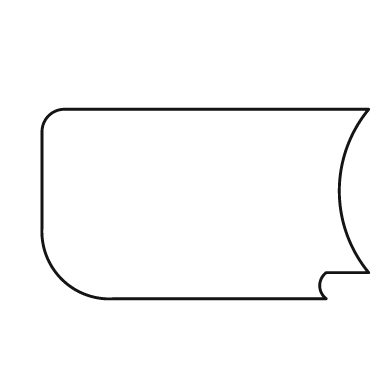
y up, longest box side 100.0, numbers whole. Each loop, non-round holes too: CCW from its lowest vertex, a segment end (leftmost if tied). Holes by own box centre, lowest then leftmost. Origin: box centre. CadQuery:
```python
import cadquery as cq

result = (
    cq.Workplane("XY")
    .moveTo(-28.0, -29.0)
    .lineTo(37.0, -29.0)
    .threePointArc((35.0, -25.0), (37.0, -21.0))
    .lineTo(50.0, -21.0)
    .threePointArc((41.0, 4.0), (50.0, 29.0))
    .lineTo(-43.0, 29.0)
    .threePointArc((-48.0, 27.0), (-50.0, 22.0))
    .lineTo(-50.0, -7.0)
    .threePointArc((-44.0, -23.0), (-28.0, -29.0))
    .close()
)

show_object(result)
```